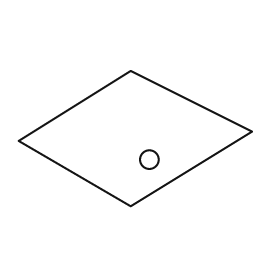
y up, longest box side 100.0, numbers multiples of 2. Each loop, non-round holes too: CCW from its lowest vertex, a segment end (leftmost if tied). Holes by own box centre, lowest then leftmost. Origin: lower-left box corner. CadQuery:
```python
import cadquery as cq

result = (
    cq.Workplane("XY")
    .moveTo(48.0, 0.0)
    .lineTo(100.0, 32.0)
    .lineTo(48.0, 58.0)
    .lineTo(0.0, 28.0)
    .close()
    .moveTo(56.0, 20.0)
    .circle(4.0)
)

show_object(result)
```